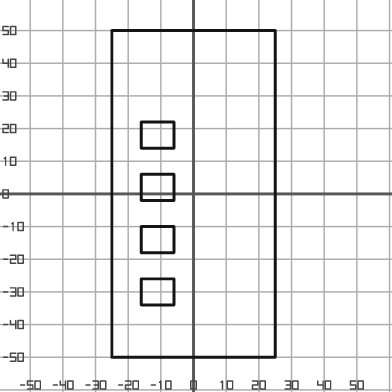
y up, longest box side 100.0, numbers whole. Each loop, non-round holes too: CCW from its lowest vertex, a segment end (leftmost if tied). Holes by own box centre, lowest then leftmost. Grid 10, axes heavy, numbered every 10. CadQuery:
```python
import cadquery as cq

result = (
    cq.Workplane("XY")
    .moveTo(-25.0, -50.0)
    .lineTo(25.0, -50.0)
    .lineTo(25.0, 50.0)
    .lineTo(-25.0, 50.0)
    .close()
    .moveTo(-16.0, -34.0)
    .lineTo(-6.0, -34.0)
    .lineTo(-6.0, -26.0)
    .lineTo(-16.0, -26.0)
    .close()
    .moveTo(-16.0, -18.0)
    .lineTo(-6.0, -18.0)
    .lineTo(-6.0, -10.0)
    .lineTo(-16.0, -10.0)
    .close()
    .moveTo(-16.0, -2.0)
    .lineTo(-6.0, -2.0)
    .lineTo(-6.0, 6.0)
    .lineTo(-16.0, 6.0)
    .close()
    .moveTo(-16.0, 14.0)
    .lineTo(-6.0, 14.0)
    .lineTo(-6.0, 22.0)
    .lineTo(-16.0, 22.0)
    .close()
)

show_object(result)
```